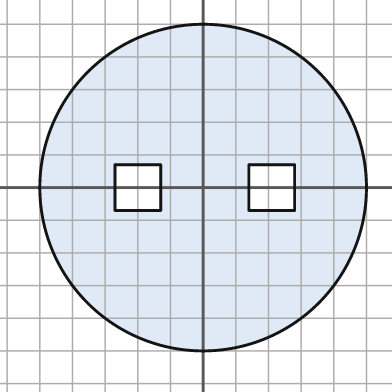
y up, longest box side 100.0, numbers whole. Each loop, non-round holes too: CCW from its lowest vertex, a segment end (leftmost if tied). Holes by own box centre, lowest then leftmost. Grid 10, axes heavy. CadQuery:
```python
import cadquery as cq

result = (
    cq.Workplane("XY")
    .moveTo(0.0, 0.0)
    .circle(50.0)
    .moveTo(-27.0, -7.0)
    .lineTo(-13.0, -7.0)
    .lineTo(-13.0, 7.0)
    .lineTo(-27.0, 7.0)
    .close()
    .moveTo(14.0, -7.0)
    .lineTo(28.0, -7.0)
    .lineTo(28.0, 7.0)
    .lineTo(14.0, 7.0)
    .close()
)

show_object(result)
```